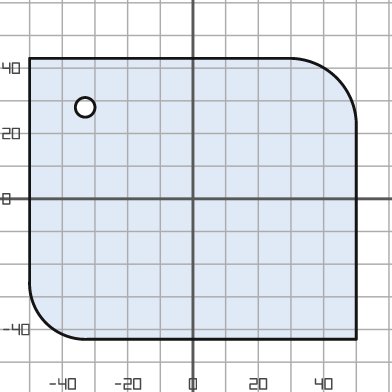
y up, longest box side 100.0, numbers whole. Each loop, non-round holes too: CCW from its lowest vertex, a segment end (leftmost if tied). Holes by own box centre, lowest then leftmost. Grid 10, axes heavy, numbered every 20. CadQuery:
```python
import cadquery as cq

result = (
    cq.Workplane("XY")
    .moveTo(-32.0, -43.0)
    .lineTo(50.0, -43.0)
    .lineTo(50.0, 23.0)
    .threePointArc((44.0, 37.0), (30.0, 43.0))
    .lineTo(-50.0, 43.0)
    .lineTo(-50.0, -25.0)
    .threePointArc((-45.0, -38.0), (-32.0, -43.0))
    .close()
    .moveTo(-33.0, 28.0)
    .circle(3.0)
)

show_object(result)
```